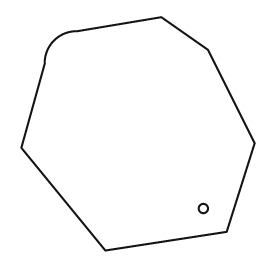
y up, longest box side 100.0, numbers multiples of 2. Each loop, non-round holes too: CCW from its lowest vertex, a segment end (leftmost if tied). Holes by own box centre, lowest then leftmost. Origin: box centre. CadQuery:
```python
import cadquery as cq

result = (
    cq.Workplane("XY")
    .moveTo(-14.0, -50.0)
    .lineTo(38.0, -42.0)
    .lineTo(50.0, -4.0)
    .lineTo(30.0, 36.0)
    .lineTo(10.0, 50.0)
    .lineTo(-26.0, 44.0)
    .threePointArc((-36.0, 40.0), (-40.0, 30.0))
    .lineTo(-50.0, -6.0)
    .close()
    .moveTo(28.0, -32.0)
    .circle(2.0)
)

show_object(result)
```